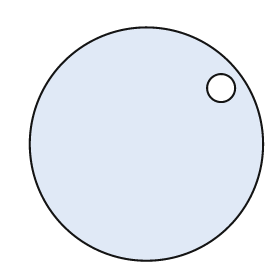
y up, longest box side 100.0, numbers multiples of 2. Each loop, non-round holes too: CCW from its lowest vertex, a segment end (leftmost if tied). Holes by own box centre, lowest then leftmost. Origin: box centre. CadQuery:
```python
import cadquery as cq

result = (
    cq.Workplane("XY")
    .moveTo(0.0, 0.0)
    .circle(50.0)
    .moveTo(32.0, 24.0)
    .circle(6.0)
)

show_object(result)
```